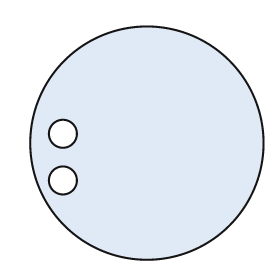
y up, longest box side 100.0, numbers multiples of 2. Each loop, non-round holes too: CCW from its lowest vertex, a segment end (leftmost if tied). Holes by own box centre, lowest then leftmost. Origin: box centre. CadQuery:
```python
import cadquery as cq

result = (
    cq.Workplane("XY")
    .moveTo(0.0, 0.0)
    .circle(50.0)
    .moveTo(-36.0, -16.0)
    .circle(6.0)
    .moveTo(-36.0, 4.0)
    .circle(6.0)
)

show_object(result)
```